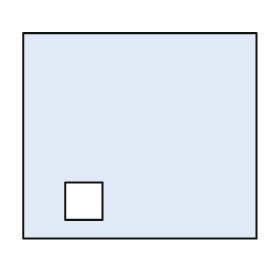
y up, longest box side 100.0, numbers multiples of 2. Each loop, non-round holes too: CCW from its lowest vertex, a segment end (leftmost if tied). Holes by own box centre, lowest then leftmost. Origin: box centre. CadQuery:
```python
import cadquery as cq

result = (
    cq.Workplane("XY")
    .moveTo(-50.0, -44.0)
    .lineTo(50.0, -44.0)
    .lineTo(50.0, 44.0)
    .lineTo(-50.0, 44.0)
    .close()
    .moveTo(-32.0, -36.0)
    .lineTo(-16.0, -36.0)
    .lineTo(-16.0, -20.0)
    .lineTo(-32.0, -20.0)
    .close()
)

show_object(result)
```